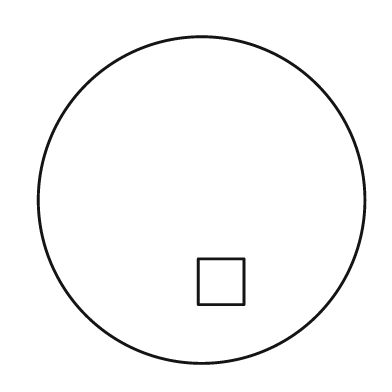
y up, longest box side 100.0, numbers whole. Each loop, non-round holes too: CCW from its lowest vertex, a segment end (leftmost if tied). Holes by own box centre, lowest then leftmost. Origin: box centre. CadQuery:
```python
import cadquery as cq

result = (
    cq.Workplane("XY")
    .moveTo(0.0, 0.0)
    .circle(50.0)
    .moveTo(-1.0, -32.0)
    .lineTo(13.0, -32.0)
    .lineTo(13.0, -18.0)
    .lineTo(-1.0, -18.0)
    .close()
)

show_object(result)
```